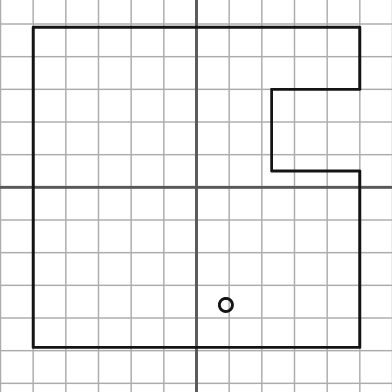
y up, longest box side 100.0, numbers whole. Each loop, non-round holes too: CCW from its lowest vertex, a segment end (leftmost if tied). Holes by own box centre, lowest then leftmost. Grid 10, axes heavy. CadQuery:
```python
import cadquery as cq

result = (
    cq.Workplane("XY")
    .moveTo(-50.0, -49.0)
    .lineTo(50.0, -49.0)
    .lineTo(50.0, 5.0)
    .lineTo(23.0, 5.0)
    .lineTo(23.0, 30.0)
    .lineTo(50.0, 30.0)
    .lineTo(50.0, 49.0)
    .lineTo(-50.0, 49.0)
    .close()
    .moveTo(9.0, -36.0)
    .circle(2.0)
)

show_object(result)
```